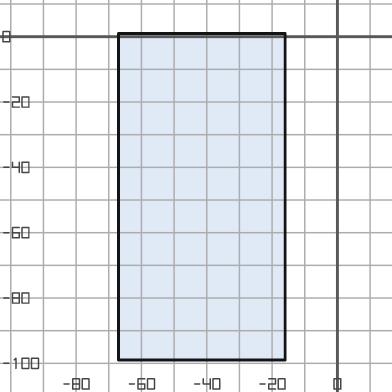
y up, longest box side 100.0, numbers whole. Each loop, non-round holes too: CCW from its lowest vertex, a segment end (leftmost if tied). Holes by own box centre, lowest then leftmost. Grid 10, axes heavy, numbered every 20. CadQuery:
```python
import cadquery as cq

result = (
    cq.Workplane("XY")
    .moveTo(-67.0, -99.0)
    .lineTo(-16.0, -99.0)
    .lineTo(-16.0, 1.0)
    .lineTo(-67.0, 1.0)
    .close()
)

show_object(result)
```